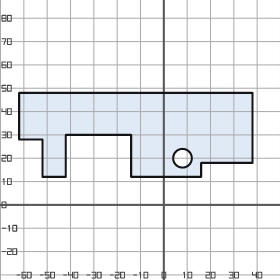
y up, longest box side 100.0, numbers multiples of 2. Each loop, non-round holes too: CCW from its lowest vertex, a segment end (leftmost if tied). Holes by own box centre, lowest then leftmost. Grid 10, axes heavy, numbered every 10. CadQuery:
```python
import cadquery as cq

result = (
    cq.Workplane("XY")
    .moveTo(-52.0, 12.0)
    .lineTo(-42.0, 12.0)
    .lineTo(-42.0, 30.0)
    .lineTo(-14.0, 30.0)
    .lineTo(-14.0, 12.0)
    .lineTo(16.0, 12.0)
    .lineTo(16.0, 18.0)
    .lineTo(38.0, 18.0)
    .lineTo(38.0, 48.0)
    .lineTo(-62.0, 48.0)
    .lineTo(-62.0, 28.0)
    .lineTo(-52.0, 28.0)
    .close()
    .moveTo(8.0, 20.0)
    .circle(4.0)
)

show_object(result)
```